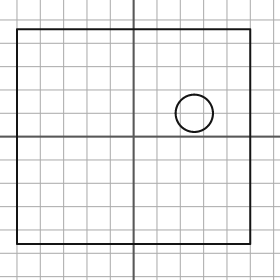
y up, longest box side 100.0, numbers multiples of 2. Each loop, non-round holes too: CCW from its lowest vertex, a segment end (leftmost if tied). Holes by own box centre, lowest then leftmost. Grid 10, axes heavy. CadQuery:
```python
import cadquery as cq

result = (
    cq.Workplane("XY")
    .moveTo(-50.0, -46.0)
    .lineTo(50.0, -46.0)
    .lineTo(50.0, 46.0)
    .lineTo(-50.0, 46.0)
    .close()
    .moveTo(26.0, 10.0)
    .circle(8.0)
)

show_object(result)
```